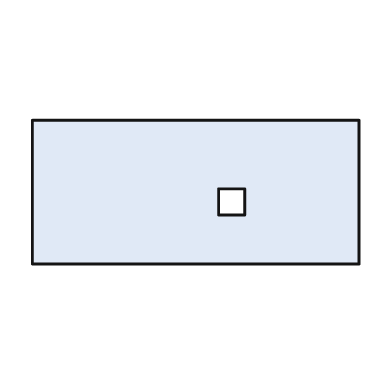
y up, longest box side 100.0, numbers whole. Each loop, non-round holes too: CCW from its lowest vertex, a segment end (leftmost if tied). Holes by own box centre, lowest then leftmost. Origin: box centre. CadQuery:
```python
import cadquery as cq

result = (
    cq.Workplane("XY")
    .moveTo(-50.0, -22.0)
    .lineTo(50.0, -22.0)
    .lineTo(50.0, 22.0)
    .lineTo(-50.0, 22.0)
    .close()
    .moveTo(7.0, -7.0)
    .lineTo(15.0, -7.0)
    .lineTo(15.0, 1.0)
    .lineTo(7.0, 1.0)
    .close()
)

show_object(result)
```